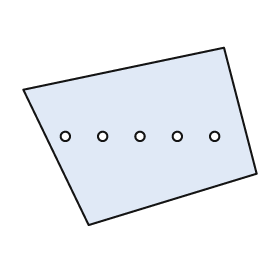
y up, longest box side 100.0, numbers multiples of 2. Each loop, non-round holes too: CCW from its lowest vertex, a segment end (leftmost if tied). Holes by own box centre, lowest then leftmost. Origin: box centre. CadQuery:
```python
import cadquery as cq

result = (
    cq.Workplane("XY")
    .moveTo(-22.0, -38.0)
    .lineTo(50.0, -16.0)
    .lineTo(36.0, 38.0)
    .lineTo(-50.0, 20.0)
    .close()
    .moveTo(-32.0, 0.0)
    .circle(2.0)
    .moveTo(-16.0, 0.0)
    .circle(2.0)
    .moveTo(0.0, 0.0)
    .circle(2.0)
    .moveTo(16.0, 0.0)
    .circle(2.0)
    .moveTo(32.0, 0.0)
    .circle(2.0)
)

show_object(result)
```